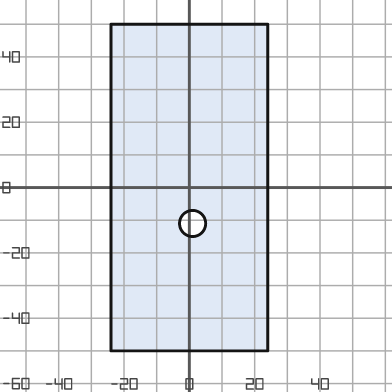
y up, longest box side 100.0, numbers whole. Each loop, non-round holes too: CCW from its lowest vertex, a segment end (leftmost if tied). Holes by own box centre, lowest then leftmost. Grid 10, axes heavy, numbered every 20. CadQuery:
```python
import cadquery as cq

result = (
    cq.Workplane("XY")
    .moveTo(-24.0, -50.0)
    .lineTo(24.0, -50.0)
    .lineTo(24.0, 50.0)
    .lineTo(-24.0, 50.0)
    .close()
    .moveTo(1.0, -11.0)
    .circle(4.0)
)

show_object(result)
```